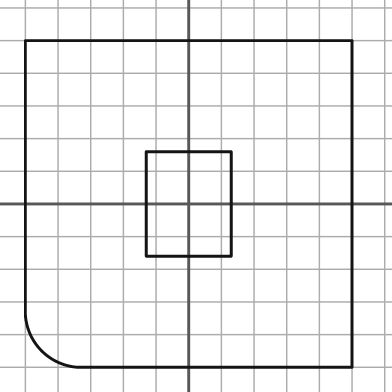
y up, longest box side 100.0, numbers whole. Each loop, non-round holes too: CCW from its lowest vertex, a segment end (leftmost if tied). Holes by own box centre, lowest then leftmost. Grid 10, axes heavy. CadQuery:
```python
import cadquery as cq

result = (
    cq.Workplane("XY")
    .moveTo(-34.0, -50.0)
    .lineTo(50.0, -50.0)
    .lineTo(50.0, 50.0)
    .lineTo(-50.0, 50.0)
    .lineTo(-50.0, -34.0)
    .threePointArc((-45.0, -45.0), (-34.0, -50.0))
    .close()
    .moveTo(-13.0, -16.0)
    .lineTo(13.0, -16.0)
    .lineTo(13.0, 16.0)
    .lineTo(-13.0, 16.0)
    .close()
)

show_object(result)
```